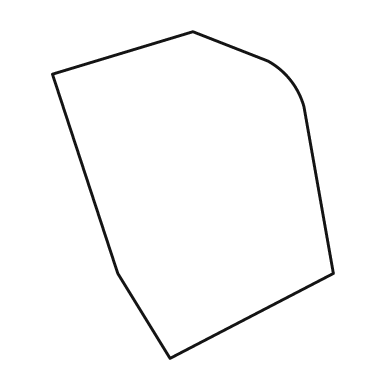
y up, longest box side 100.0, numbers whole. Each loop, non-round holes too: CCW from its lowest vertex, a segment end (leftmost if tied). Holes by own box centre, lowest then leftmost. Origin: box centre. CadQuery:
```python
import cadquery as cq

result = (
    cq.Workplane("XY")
    .moveTo(-7.0, -50.0)
    .lineTo(43.0, -24.0)
    .lineTo(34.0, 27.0)
    .threePointArc((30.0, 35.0), (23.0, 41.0))
    .lineTo(0.0, 50.0)
    .lineTo(-43.0, 37.0)
    .lineTo(-23.0, -24.0)
    .close()
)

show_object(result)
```